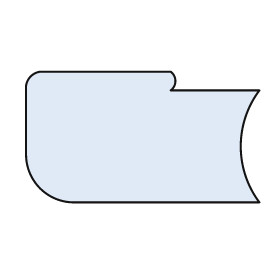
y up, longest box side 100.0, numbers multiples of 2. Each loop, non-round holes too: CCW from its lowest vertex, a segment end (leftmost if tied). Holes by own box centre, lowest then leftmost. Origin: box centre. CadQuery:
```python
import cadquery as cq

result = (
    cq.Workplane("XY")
    .moveTo(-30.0, -28.0)
    .lineTo(50.0, -28.0)
    .threePointArc((42.0, -4.0), (50.0, 20.0))
    .lineTo(12.0, 20.0)
    .threePointArc((14.0, 24.0), (12.0, 28.0))
    .lineTo(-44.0, 28.0)
    .threePointArc((-48.0, 26.0), (-50.0, 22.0))
    .lineTo(-50.0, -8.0)
    .threePointArc((-44.0, -22.0), (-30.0, -28.0))
    .close()
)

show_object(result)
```